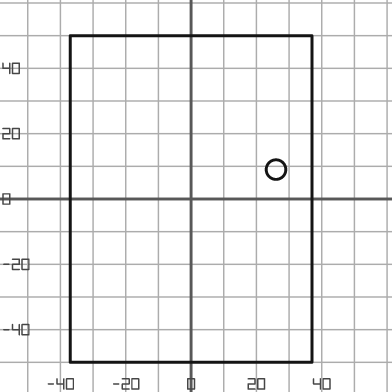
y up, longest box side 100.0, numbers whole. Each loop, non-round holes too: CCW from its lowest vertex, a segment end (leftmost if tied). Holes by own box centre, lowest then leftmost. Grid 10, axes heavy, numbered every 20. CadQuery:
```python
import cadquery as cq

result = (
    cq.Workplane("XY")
    .moveTo(-37.0, -50.0)
    .lineTo(37.0, -50.0)
    .lineTo(37.0, 50.0)
    .lineTo(-37.0, 50.0)
    .close()
    .moveTo(26.0, 9.0)
    .circle(3.0)
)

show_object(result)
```